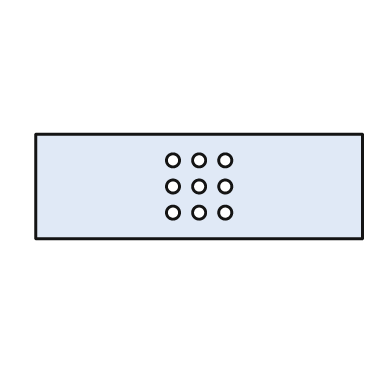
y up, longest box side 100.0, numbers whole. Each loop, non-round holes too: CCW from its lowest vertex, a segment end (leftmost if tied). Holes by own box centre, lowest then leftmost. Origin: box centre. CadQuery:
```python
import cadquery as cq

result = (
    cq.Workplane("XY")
    .moveTo(-50.0, -16.0)
    .lineTo(50.0, -16.0)
    .lineTo(50.0, 16.0)
    .lineTo(-50.0, 16.0)
    .close()
    .moveTo(-8.0, -8.0)
    .circle(2.0)
    .moveTo(0.0, -8.0)
    .circle(2.0)
    .moveTo(8.0, -8.0)
    .circle(2.0)
    .moveTo(-8.0, 0.0)
    .circle(2.0)
    .moveTo(0.0, 0.0)
    .circle(2.0)
    .moveTo(8.0, 0.0)
    .circle(2.0)
    .moveTo(-8.0, 8.0)
    .circle(2.0)
    .moveTo(0.0, 8.0)
    .circle(2.0)
    .moveTo(8.0, 8.0)
    .circle(2.0)
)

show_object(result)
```